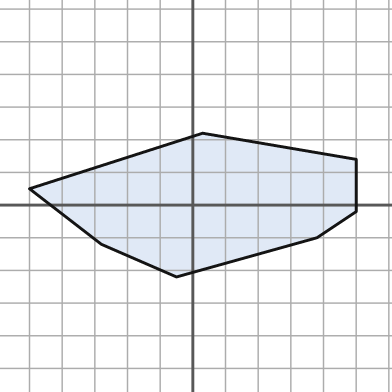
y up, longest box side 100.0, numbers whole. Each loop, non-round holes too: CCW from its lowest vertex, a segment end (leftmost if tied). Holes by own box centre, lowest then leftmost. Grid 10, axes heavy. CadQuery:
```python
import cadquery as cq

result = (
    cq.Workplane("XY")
    .moveTo(-5.0, -22.0)
    .lineTo(38.0, -10.0)
    .lineTo(50.0, -2.0)
    .lineTo(50.0, 14.0)
    .lineTo(3.0, 22.0)
    .lineTo(-50.0, 5.0)
    .lineTo(-28.0, -12.0)
    .close()
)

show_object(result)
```